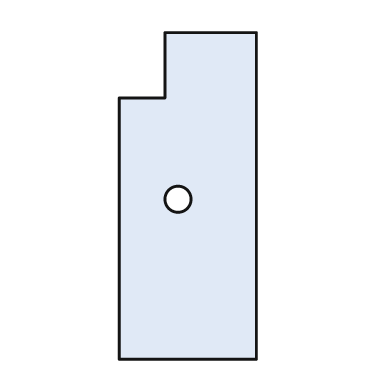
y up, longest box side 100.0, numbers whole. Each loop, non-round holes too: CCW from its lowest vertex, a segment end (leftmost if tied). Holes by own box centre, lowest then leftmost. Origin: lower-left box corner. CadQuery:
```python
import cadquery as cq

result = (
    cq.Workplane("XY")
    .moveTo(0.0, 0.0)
    .lineTo(42.0, 0.0)
    .lineTo(42.0, 100.0)
    .lineTo(14.0, 100.0)
    .lineTo(14.0, 80.0)
    .lineTo(0.0, 80.0)
    .close()
    .moveTo(18.0, 49.0)
    .circle(4.0)
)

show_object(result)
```